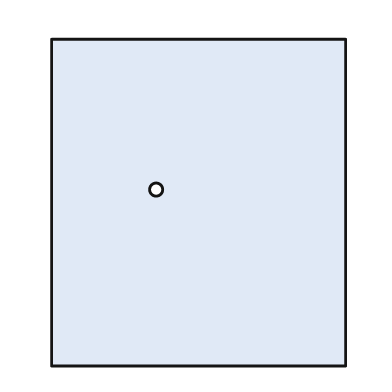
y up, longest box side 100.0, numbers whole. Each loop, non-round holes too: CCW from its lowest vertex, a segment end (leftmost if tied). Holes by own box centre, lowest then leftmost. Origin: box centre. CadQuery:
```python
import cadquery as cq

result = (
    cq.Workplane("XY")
    .moveTo(-45.0, -50.0)
    .lineTo(45.0, -50.0)
    .lineTo(45.0, 50.0)
    .lineTo(-45.0, 50.0)
    .close()
    .moveTo(-13.0, 4.0)
    .circle(2.0)
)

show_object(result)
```